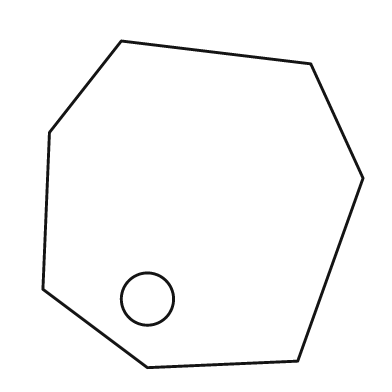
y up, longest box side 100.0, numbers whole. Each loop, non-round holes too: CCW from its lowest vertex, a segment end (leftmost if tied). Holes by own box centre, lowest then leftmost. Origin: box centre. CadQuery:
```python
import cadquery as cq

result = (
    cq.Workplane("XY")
    .moveTo(-17.0, -50.0)
    .lineTo(29.0, -48.0)
    .lineTo(49.0, 8.0)
    .lineTo(33.0, 43.0)
    .lineTo(-25.0, 50.0)
    .lineTo(-47.0, 22.0)
    .lineTo(-49.0, -26.0)
    .close()
    .moveTo(-17.0, -29.0)
    .circle(8.0)
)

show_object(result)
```